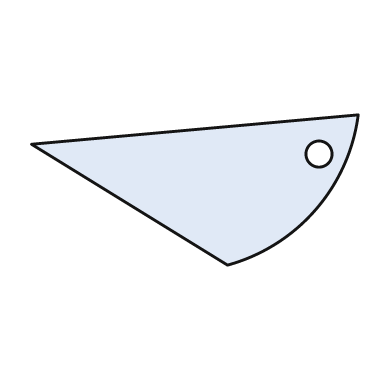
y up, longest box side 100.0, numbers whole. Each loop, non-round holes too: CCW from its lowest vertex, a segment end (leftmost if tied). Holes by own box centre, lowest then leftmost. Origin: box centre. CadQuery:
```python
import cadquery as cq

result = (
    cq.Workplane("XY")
    .moveTo(10.0, -23.0)
    .threePointArc((37.0, -6.0), (50.0, 23.0))
    .lineTo(-50.0, 14.0)
    .close()
    .moveTo(38.0, 11.0)
    .circle(4.0)
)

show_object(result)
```